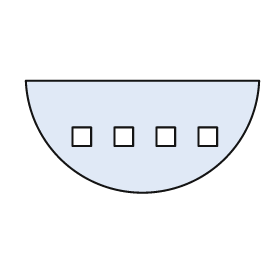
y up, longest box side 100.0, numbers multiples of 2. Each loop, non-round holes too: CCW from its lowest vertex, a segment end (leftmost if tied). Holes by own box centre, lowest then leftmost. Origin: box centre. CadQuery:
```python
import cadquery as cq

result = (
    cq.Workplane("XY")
    .moveTo(-50.0, 24.0)
    .threePointArc((0.0, -24.0), (50.0, 24.0))
    .close()
    .moveTo(-30.0, -4.0)
    .lineTo(-22.0, -4.0)
    .lineTo(-22.0, 4.0)
    .lineTo(-30.0, 4.0)
    .close()
    .moveTo(-12.0, -4.0)
    .lineTo(-4.0, -4.0)
    .lineTo(-4.0, 4.0)
    .lineTo(-12.0, 4.0)
    .close()
    .moveTo(6.0, -4.0)
    .lineTo(14.0, -4.0)
    .lineTo(14.0, 4.0)
    .lineTo(6.0, 4.0)
    .close()
    .moveTo(24.0, -4.0)
    .lineTo(32.0, -4.0)
    .lineTo(32.0, 4.0)
    .lineTo(24.0, 4.0)
    .close()
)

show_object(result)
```